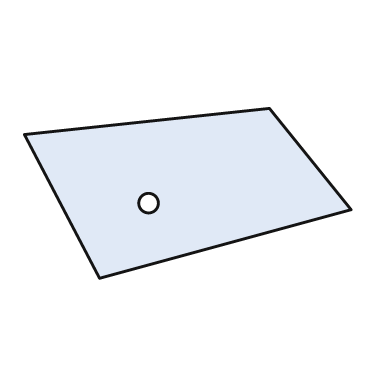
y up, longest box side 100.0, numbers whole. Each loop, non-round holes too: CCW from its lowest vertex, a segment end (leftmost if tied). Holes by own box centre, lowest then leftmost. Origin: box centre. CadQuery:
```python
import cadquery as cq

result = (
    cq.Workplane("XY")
    .moveTo(-27.0, -26.0)
    .lineTo(50.0, -5.0)
    .lineTo(25.0, 26.0)
    .lineTo(-50.0, 18.0)
    .close()
    .moveTo(-12.0, -3.0)
    .circle(3.0)
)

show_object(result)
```